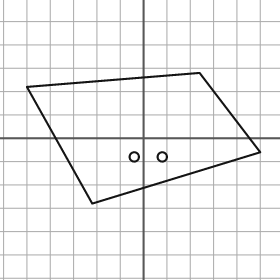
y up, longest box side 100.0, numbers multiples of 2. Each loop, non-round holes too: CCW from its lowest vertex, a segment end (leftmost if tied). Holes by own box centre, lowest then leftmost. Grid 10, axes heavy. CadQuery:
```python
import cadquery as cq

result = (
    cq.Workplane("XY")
    .moveTo(-22.0, -28.0)
    .lineTo(50.0, -6.0)
    .lineTo(24.0, 28.0)
    .lineTo(-50.0, 22.0)
    .close()
    .moveTo(-4.0, -8.0)
    .circle(2.0)
    .moveTo(8.0, -8.0)
    .circle(2.0)
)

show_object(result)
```